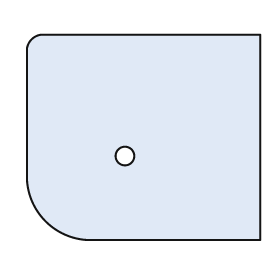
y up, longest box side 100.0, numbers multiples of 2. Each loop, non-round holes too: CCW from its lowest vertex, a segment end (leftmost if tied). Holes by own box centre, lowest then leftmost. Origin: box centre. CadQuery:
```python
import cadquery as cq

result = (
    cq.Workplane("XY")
    .moveTo(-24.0, -44.0)
    .lineTo(50.0, -44.0)
    .lineTo(50.0, 44.0)
    .lineTo(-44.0, 44.0)
    .threePointArc((-48.0, 42.0), (-50.0, 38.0))
    .lineTo(-50.0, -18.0)
    .threePointArc((-42.0, -36.0), (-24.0, -44.0))
    .close()
    .moveTo(-8.0, -8.0)
    .circle(4.0)
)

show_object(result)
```